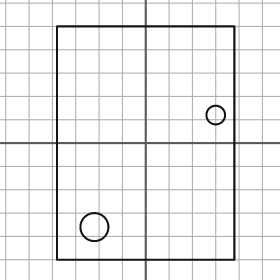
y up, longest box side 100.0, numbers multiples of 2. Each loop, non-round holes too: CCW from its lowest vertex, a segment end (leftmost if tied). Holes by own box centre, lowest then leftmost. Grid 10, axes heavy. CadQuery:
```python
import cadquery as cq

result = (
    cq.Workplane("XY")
    .moveTo(-38.0, -50.0)
    .lineTo(38.0, -50.0)
    .lineTo(38.0, 50.0)
    .lineTo(-38.0, 50.0)
    .close()
    .moveTo(-22.0, -36.0)
    .circle(6.0)
    .moveTo(30.0, 12.0)
    .circle(4.0)
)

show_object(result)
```